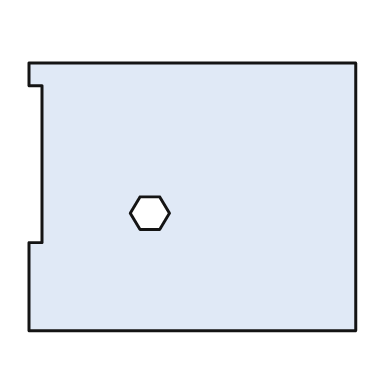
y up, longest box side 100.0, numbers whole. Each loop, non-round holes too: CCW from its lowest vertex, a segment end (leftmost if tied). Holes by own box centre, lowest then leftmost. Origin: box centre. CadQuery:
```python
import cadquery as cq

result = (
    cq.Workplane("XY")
    .moveTo(-50.0, -41.0)
    .lineTo(50.0, -41.0)
    .lineTo(50.0, 41.0)
    .lineTo(-50.0, 41.0)
    .lineTo(-50.0, 34.0)
    .lineTo(-46.0, 34.0)
    .lineTo(-46.0, -14.0)
    .lineTo(-50.0, -14.0)
    .close()
    .moveTo(-16.0, -10.0)
    .lineTo(-10.0, -10.0)
    .lineTo(-7.0, -5.0)
    .lineTo(-10.0, 0.0)
    .lineTo(-16.0, 0.0)
    .lineTo(-19.0, -5.0)
    .close()
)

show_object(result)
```